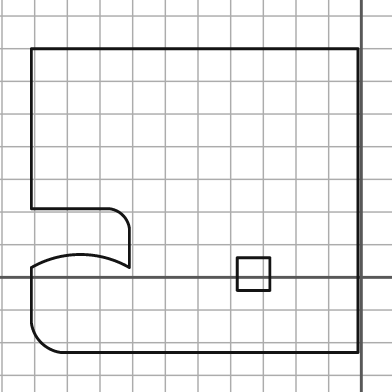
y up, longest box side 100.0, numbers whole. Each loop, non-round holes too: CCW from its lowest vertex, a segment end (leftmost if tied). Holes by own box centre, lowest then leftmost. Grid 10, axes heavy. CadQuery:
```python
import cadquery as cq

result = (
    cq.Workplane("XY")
    .moveTo(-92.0, -23.0)
    .lineTo(-1.0, -23.0)
    .lineTo(-1.0, 70.0)
    .lineTo(-101.0, 70.0)
    .lineTo(-101.0, 21.0)
    .lineTo(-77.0, 21.0)
    .threePointArc((-73.0, 19.0), (-71.0, 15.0))
    .lineTo(-71.0, 3.0)
    .threePointArc((-86.0, 7.0), (-101.0, 3.0))
    .lineTo(-101.0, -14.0)
    .threePointArc((-98.0, -20.0), (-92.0, -23.0))
    .close()
    .moveTo(-38.0, -4.0)
    .lineTo(-28.0, -4.0)
    .lineTo(-28.0, 6.0)
    .lineTo(-38.0, 6.0)
    .close()
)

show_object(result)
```